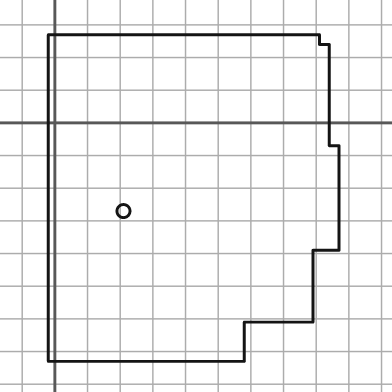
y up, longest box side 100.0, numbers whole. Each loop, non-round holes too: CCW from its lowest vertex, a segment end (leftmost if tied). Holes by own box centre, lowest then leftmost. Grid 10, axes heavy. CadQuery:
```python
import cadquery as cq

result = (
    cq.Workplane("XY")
    .moveTo(-2.0, -73.0)
    .lineTo(58.0, -73.0)
    .lineTo(58.0, -61.0)
    .lineTo(79.0, -61.0)
    .lineTo(79.0, -39.0)
    .lineTo(87.0, -39.0)
    .lineTo(87.0, -7.0)
    .lineTo(84.0, -7.0)
    .lineTo(84.0, 24.0)
    .lineTo(81.0, 24.0)
    .lineTo(81.0, 27.0)
    .lineTo(-2.0, 27.0)
    .close()
    .moveTo(21.0, -27.0)
    .circle(2.0)
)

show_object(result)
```